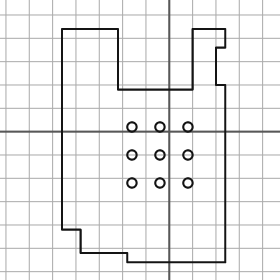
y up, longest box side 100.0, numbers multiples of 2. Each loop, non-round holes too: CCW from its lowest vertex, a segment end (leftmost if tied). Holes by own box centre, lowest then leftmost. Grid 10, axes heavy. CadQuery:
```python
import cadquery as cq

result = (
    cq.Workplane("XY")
    .moveTo(-18.0, -56.0)
    .lineTo(24.0, -56.0)
    .lineTo(24.0, 20.0)
    .lineTo(20.0, 20.0)
    .lineTo(20.0, 36.0)
    .lineTo(24.0, 36.0)
    .lineTo(24.0, 44.0)
    .lineTo(10.0, 44.0)
    .lineTo(10.0, 18.0)
    .lineTo(-22.0, 18.0)
    .lineTo(-22.0, 44.0)
    .lineTo(-46.0, 44.0)
    .lineTo(-46.0, -42.0)
    .lineTo(-38.0, -42.0)
    .lineTo(-38.0, -52.0)
    .lineTo(-18.0, -52.0)
    .close()
    .moveTo(-16.0, -22.0)
    .circle(2.0)
    .moveTo(-4.0, -22.0)
    .circle(2.0)
    .moveTo(8.0, -22.0)
    .circle(2.0)
    .moveTo(-16.0, -10.0)
    .circle(2.0)
    .moveTo(-4.0, -10.0)
    .circle(2.0)
    .moveTo(8.0, -10.0)
    .circle(2.0)
    .moveTo(-16.0, 2.0)
    .circle(2.0)
    .moveTo(-4.0, 2.0)
    .circle(2.0)
    .moveTo(8.0, 2.0)
    .circle(2.0)
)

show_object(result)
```